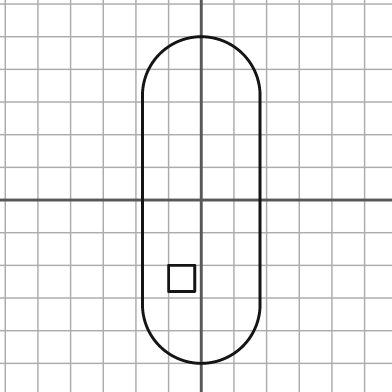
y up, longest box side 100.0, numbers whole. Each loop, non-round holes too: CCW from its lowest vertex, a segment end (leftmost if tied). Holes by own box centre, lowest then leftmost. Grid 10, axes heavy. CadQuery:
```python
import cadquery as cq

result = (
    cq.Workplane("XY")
    .moveTo(-18.0, -32.0)
    .threePointArc((0.0, -50.0), (18.0, -32.0))
    .lineTo(18.0, 32.0)
    .threePointArc((0.0, 50.0), (-18.0, 32.0))
    .close()
    .moveTo(-10.0, -28.0)
    .lineTo(-2.0, -28.0)
    .lineTo(-2.0, -20.0)
    .lineTo(-10.0, -20.0)
    .close()
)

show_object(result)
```